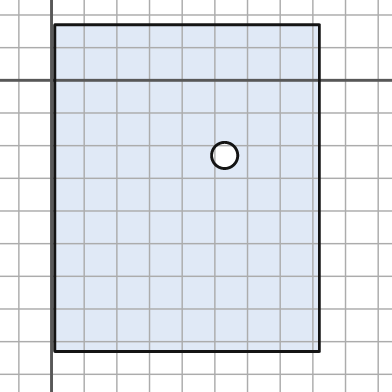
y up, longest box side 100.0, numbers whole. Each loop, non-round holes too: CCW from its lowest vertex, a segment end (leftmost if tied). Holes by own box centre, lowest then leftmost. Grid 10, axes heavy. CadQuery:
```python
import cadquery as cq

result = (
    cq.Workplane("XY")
    .moveTo(1.0, -83.0)
    .lineTo(82.0, -83.0)
    .lineTo(82.0, 17.0)
    .lineTo(1.0, 17.0)
    .close()
    .moveTo(53.0, -23.0)
    .circle(4.0)
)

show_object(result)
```